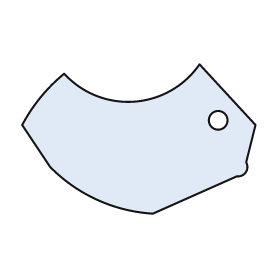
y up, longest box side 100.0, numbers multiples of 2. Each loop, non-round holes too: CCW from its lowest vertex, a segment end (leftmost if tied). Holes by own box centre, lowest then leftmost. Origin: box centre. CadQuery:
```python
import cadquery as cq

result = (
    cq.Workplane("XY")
    .moveTo(6.0, -32.0)
    .lineTo(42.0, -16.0)
    .threePointArc((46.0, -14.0), (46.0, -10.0))
    .lineTo(50.0, 6.0)
    .lineTo(26.0, 32.0)
    .threePointArc((-2.0, 16.0), (-32.0, 28.0))
    .threePointArc((-42.0, 18.0), (-50.0, 6.0))
    .lineTo(-38.0, -12.0)
    .threePointArc((-18.0, -26.0), (6.0, -32.0))
    .close()
    .moveTo(34.0, 8.0)
    .circle(4.0)
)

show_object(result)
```